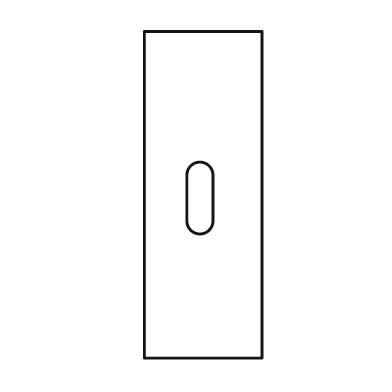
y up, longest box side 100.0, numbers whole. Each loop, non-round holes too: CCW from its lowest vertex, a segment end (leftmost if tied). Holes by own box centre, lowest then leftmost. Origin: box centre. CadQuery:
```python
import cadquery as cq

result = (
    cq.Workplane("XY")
    .moveTo(-18.0, -50.0)
    .lineTo(18.0, -50.0)
    .lineTo(18.0, 50.0)
    .lineTo(-18.0, 50.0)
    .close()
    .moveTo(-5.0, -8.0)
    .threePointArc((-1.0, -12.0), (3.0, -8.0))
    .lineTo(3.0, 6.0)
    .threePointArc((-1.0, 10.0), (-5.0, 6.0))
    .close()
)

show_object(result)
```